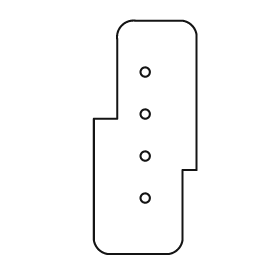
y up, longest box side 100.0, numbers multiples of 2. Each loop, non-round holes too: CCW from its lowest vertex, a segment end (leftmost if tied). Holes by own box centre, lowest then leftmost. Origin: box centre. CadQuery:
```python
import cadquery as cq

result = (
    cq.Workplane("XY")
    .moveTo(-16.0, -50.0)
    .lineTo(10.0, -50.0)
    .threePointArc((14.0, -48.0), (16.0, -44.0))
    .lineTo(16.0, -14.0)
    .lineTo(22.0, -14.0)
    .lineTo(22.0, 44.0)
    .threePointArc((20.0, 48.0), (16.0, 50.0))
    .lineTo(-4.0, 50.0)
    .threePointArc((-10.0, 48.0), (-12.0, 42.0))
    .lineTo(-12.0, 8.0)
    .lineTo(-22.0, 8.0)
    .lineTo(-22.0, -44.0)
    .threePointArc((-20.0, -48.0), (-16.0, -50.0))
    .close()
    .moveTo(0.0, -26.0)
    .circle(2.0)
    .moveTo(0.0, -8.0)
    .circle(2.0)
    .moveTo(0.0, 10.0)
    .circle(2.0)
    .moveTo(0.0, 28.0)
    .circle(2.0)
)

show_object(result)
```